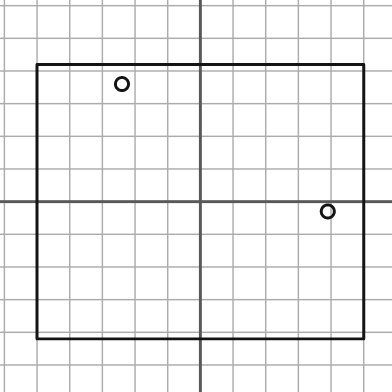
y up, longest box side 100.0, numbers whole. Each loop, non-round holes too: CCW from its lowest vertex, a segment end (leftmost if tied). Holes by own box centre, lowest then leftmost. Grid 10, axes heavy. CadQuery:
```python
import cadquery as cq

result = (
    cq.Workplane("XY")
    .moveTo(-50.0, -42.0)
    .lineTo(50.0, -42.0)
    .lineTo(50.0, 42.0)
    .lineTo(-50.0, 42.0)
    .close()
    .moveTo(39.0, -3.0)
    .circle(2.0)
    .moveTo(-24.0, 36.0)
    .circle(2.0)
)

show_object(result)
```